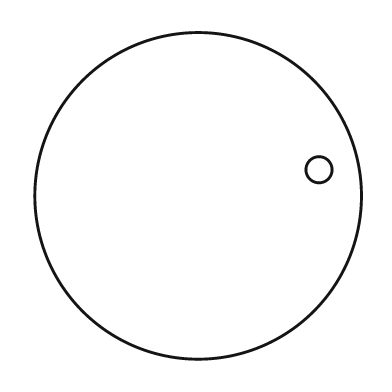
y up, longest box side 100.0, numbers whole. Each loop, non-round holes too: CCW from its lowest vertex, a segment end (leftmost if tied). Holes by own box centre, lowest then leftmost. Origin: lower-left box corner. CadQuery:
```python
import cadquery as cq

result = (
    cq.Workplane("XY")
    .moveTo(50.0, 50.0)
    .circle(50.0)
    .moveTo(87.0, 58.0)
    .circle(4.0)
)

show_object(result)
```